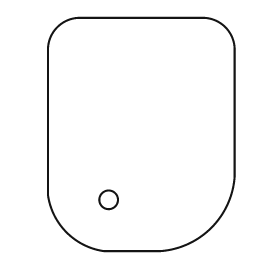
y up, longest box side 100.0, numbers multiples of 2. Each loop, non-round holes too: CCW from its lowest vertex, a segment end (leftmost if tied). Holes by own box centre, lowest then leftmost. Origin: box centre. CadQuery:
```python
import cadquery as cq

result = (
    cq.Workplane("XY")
    .moveTo(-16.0, -50.0)
    .lineTo(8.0, -50.0)
    .threePointArc((30.0, -40.0), (40.0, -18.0))
    .lineTo(40.0, 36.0)
    .threePointArc((36.0, 46.0), (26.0, 50.0))
    .lineTo(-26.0, 50.0)
    .threePointArc((-36.0, 46.0), (-40.0, 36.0))
    .lineTo(-40.0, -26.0)
    .threePointArc((-32.0, -42.0), (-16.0, -50.0))
    .close()
    .moveTo(-14.0, -28.0)
    .circle(4.0)
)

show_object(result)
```